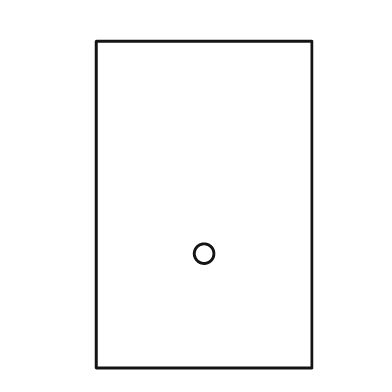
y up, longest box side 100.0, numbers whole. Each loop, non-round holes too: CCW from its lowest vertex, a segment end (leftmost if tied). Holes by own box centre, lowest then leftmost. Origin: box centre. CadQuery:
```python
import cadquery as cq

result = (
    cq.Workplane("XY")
    .moveTo(-33.0, -50.0)
    .lineTo(33.0, -50.0)
    .lineTo(33.0, 50.0)
    .lineTo(-33.0, 50.0)
    .close()
    .moveTo(0.0, -15.0)
    .circle(3.0)
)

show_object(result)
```